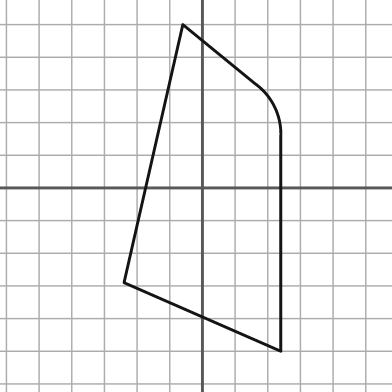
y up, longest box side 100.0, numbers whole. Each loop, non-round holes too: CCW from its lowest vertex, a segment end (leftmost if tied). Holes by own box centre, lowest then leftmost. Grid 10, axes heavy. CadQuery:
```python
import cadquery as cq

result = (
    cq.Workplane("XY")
    .moveTo(24.0, -50.0)
    .lineTo(24.0, 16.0)
    .threePointArc((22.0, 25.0), (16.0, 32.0))
    .lineTo(-6.0, 50.0)
    .lineTo(-24.0, -29.0)
    .close()
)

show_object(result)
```